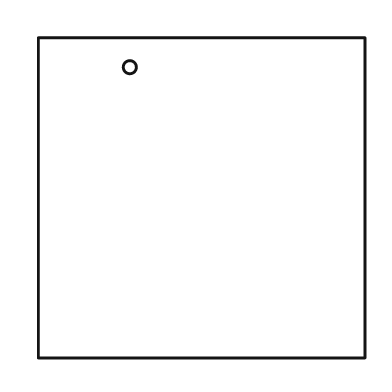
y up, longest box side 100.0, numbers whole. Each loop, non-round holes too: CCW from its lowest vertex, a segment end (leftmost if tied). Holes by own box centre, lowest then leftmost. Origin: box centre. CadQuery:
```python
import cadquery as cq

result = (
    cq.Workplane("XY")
    .moveTo(-50.0, -49.0)
    .lineTo(50.0, -49.0)
    .lineTo(50.0, 49.0)
    .lineTo(-50.0, 49.0)
    .close()
    .moveTo(-22.0, 40.0)
    .circle(2.0)
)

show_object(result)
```